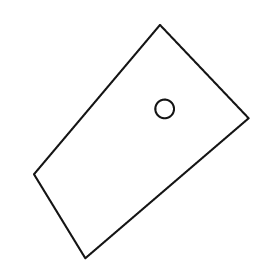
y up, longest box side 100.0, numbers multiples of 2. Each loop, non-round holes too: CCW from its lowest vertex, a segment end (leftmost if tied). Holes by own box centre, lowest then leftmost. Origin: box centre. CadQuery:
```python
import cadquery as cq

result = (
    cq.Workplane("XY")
    .moveTo(-24.0, -50.0)
    .lineTo(46.0, 10.0)
    .lineTo(8.0, 50.0)
    .lineTo(-46.0, -14.0)
    .close()
    .moveTo(10.0, 14.0)
    .circle(4.0)
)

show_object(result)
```